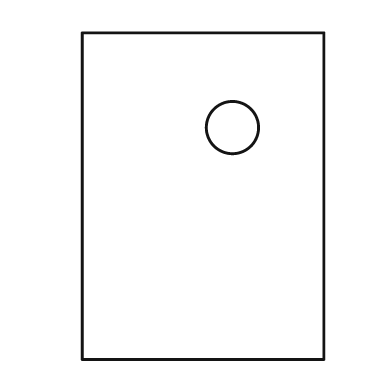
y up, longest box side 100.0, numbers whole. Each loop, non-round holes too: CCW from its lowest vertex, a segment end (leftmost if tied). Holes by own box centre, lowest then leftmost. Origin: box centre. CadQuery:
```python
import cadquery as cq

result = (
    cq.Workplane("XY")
    .moveTo(-37.0, -50.0)
    .lineTo(37.0, -50.0)
    .lineTo(37.0, 50.0)
    .lineTo(-37.0, 50.0)
    .close()
    .moveTo(9.0, 21.0)
    .circle(8.0)
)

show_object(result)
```